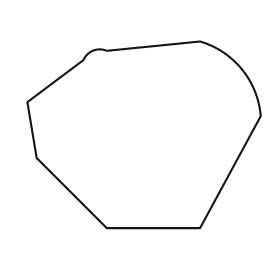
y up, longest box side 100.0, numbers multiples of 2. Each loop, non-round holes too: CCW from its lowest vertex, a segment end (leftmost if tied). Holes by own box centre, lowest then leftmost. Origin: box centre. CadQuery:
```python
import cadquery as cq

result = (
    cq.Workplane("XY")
    .moveTo(-16.0, -40.0)
    .lineTo(24.0, -40.0)
    .lineTo(50.0, 8.0)
    .threePointArc((42.0, 28.0), (24.0, 40.0))
    .lineTo(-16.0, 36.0)
    .threePointArc((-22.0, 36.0), (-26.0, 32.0))
    .lineTo(-50.0, 14.0)
    .lineTo(-46.0, -10.0)
    .close()
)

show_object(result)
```